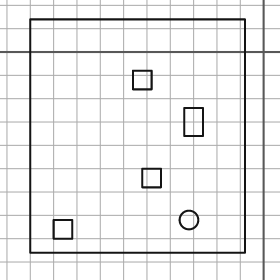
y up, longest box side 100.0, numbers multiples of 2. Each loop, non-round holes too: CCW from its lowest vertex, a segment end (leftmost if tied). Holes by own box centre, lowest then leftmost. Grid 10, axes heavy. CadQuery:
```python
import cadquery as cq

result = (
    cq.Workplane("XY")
    .moveTo(-100.0, -86.0)
    .lineTo(-8.0, -86.0)
    .lineTo(-8.0, 14.0)
    .lineTo(-100.0, 14.0)
    .close()
    .moveTo(-90.0, -80.0)
    .lineTo(-82.0, -80.0)
    .lineTo(-82.0, -72.0)
    .lineTo(-90.0, -72.0)
    .close()
    .moveTo(-32.0, -72.0)
    .circle(4.0)
    .moveTo(-52.0, -58.0)
    .lineTo(-44.0, -58.0)
    .lineTo(-44.0, -50.0)
    .lineTo(-52.0, -50.0)
    .close()
    .moveTo(-34.0, -36.0)
    .lineTo(-26.0, -36.0)
    .lineTo(-26.0, -24.0)
    .lineTo(-34.0, -24.0)
    .close()
    .moveTo(-56.0, -16.0)
    .lineTo(-48.0, -16.0)
    .lineTo(-48.0, -8.0)
    .lineTo(-56.0, -8.0)
    .close()
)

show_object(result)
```